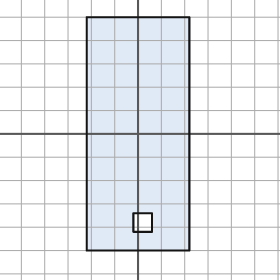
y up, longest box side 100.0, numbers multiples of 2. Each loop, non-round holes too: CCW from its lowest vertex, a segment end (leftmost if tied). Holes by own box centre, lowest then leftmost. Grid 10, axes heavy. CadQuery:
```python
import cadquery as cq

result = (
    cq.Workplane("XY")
    .moveTo(-22.0, -50.0)
    .lineTo(22.0, -50.0)
    .lineTo(22.0, 50.0)
    .lineTo(-22.0, 50.0)
    .close()
    .moveTo(-2.0, -42.0)
    .lineTo(6.0, -42.0)
    .lineTo(6.0, -34.0)
    .lineTo(-2.0, -34.0)
    .close()
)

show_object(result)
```